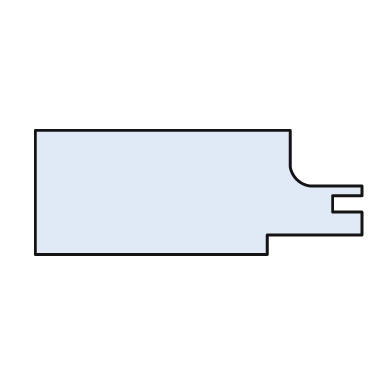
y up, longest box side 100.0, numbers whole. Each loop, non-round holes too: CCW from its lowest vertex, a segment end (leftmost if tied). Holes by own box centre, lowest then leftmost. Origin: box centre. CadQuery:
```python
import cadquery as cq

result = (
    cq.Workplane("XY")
    .moveTo(-50.0, -19.0)
    .lineTo(21.0, -19.0)
    .lineTo(21.0, -13.0)
    .lineTo(50.0, -13.0)
    .lineTo(50.0, -6.0)
    .lineTo(41.0, -6.0)
    .lineTo(41.0, -1.0)
    .lineTo(50.0, -1.0)
    .lineTo(50.0, 2.0)
    .lineTo(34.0, 2.0)
    .threePointArc((30.0, 4.0), (28.0, 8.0))
    .lineTo(28.0, 19.0)
    .lineTo(-50.0, 19.0)
    .close()
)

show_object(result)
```